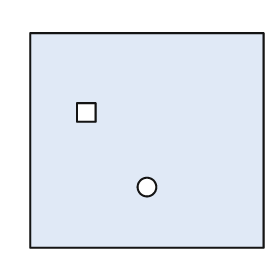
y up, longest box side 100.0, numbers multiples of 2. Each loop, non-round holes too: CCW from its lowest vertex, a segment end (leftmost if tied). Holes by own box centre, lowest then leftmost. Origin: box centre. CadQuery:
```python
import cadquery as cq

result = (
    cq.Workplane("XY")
    .moveTo(-50.0, -46.0)
    .lineTo(50.0, -46.0)
    .lineTo(50.0, 46.0)
    .lineTo(-50.0, 46.0)
    .close()
    .moveTo(0.0, -20.0)
    .circle(4.0)
    .moveTo(-30.0, 8.0)
    .lineTo(-22.0, 8.0)
    .lineTo(-22.0, 16.0)
    .lineTo(-30.0, 16.0)
    .close()
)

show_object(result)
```